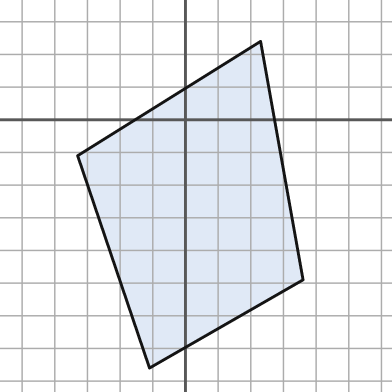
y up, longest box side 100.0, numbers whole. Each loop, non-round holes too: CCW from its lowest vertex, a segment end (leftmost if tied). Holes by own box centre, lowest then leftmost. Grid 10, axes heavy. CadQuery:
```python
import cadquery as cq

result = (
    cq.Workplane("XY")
    .moveTo(-11.0, -76.0)
    .lineTo(36.0, -49.0)
    .lineTo(23.0, 24.0)
    .lineTo(-33.0, -11.0)
    .close()
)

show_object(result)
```